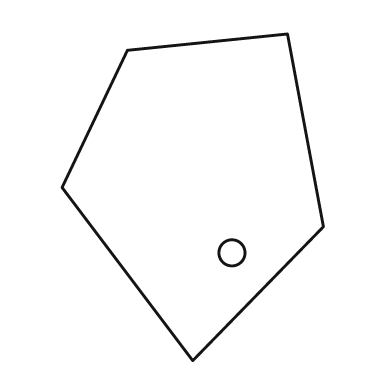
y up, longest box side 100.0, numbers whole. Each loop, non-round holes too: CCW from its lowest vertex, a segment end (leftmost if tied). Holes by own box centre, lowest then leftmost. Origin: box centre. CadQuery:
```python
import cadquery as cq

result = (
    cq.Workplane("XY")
    .moveTo(0.0, -50.0)
    .lineTo(40.0, -9.0)
    .lineTo(29.0, 50.0)
    .lineTo(-20.0, 45.0)
    .lineTo(-40.0, 3.0)
    .close()
    .moveTo(12.0, -17.0)
    .circle(4.0)
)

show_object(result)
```